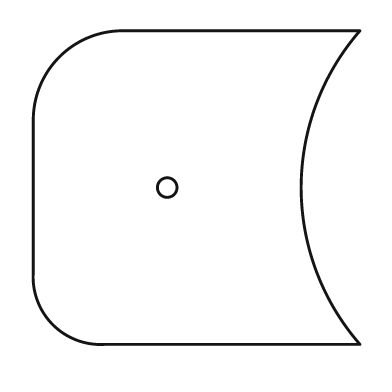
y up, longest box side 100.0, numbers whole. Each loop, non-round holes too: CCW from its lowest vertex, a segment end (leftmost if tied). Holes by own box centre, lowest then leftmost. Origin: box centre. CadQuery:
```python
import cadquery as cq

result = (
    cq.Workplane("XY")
    .moveTo(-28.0, -48.0)
    .lineTo(50.0, -48.0)
    .threePointArc((32.0, 0.0), (50.0, 48.0))
    .lineTo(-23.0, 48.0)
    .threePointArc((-42.0, 40.0), (-50.0, 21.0))
    .lineTo(-50.0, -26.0)
    .threePointArc((-44.0, -42.0), (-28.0, -48.0))
    .close()
    .moveTo(-9.0, 0.0)
    .circle(3.0)
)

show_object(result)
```